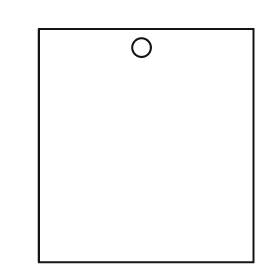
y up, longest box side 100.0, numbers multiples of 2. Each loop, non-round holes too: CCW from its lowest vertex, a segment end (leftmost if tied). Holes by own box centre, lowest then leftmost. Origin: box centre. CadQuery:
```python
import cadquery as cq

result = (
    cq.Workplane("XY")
    .moveTo(-46.0, -50.0)
    .lineTo(46.0, -50.0)
    .lineTo(46.0, 50.0)
    .lineTo(-46.0, 50.0)
    .close()
    .moveTo(-2.0, 42.0)
    .circle(4.0)
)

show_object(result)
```